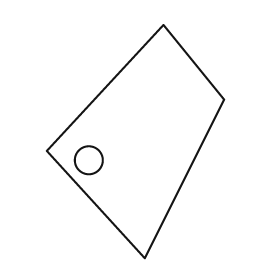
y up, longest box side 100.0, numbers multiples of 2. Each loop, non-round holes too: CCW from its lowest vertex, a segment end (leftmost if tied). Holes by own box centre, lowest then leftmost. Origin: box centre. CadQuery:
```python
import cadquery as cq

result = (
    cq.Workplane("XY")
    .moveTo(4.0, -50.0)
    .lineTo(38.0, 18.0)
    .lineTo(12.0, 50.0)
    .lineTo(-38.0, -4.0)
    .close()
    .moveTo(-20.0, -8.0)
    .circle(6.0)
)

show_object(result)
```